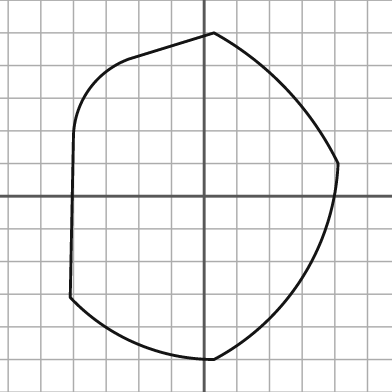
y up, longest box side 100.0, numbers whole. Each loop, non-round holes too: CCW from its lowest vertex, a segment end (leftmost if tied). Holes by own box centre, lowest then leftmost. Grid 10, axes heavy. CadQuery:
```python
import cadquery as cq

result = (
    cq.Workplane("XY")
    .moveTo(3.0, -50.0)
    .threePointArc((30.0, -25.0), (41.0, 10.0))
    .threePointArc((25.0, 33.0), (3.0, 50.0))
    .lineTo(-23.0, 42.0)
    .threePointArc((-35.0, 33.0), (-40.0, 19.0))
    .lineTo(-41.0, -31.0)
    .threePointArc((-21.0, -45.0), (3.0, -50.0))
    .close()
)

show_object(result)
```